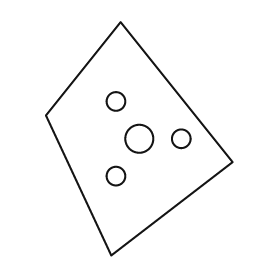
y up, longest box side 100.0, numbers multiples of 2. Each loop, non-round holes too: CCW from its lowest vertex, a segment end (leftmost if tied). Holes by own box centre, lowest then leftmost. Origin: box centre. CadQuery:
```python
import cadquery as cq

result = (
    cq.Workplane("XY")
    .moveTo(-12.0, -50.0)
    .lineTo(40.0, -10.0)
    .lineTo(-8.0, 50.0)
    .lineTo(-40.0, 10.0)
    .close()
    .moveTo(-10.0, -16.0)
    .circle(4.0)
    .moveTo(0.0, 0.0)
    .circle(6.0)
    .moveTo(18.0, 0.0)
    .circle(4.0)
    .moveTo(-10.0, 16.0)
    .circle(4.0)
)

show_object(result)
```